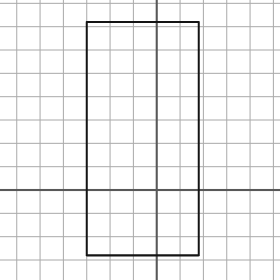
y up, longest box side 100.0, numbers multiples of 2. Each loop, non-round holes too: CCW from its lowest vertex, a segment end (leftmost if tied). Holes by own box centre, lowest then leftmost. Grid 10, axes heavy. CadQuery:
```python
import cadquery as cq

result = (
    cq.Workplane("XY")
    .moveTo(-30.0, -28.0)
    .lineTo(18.0, -28.0)
    .lineTo(18.0, 72.0)
    .lineTo(-30.0, 72.0)
    .close()
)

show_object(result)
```